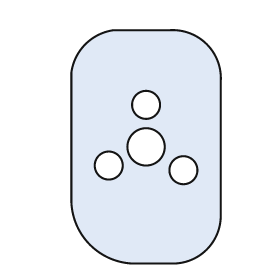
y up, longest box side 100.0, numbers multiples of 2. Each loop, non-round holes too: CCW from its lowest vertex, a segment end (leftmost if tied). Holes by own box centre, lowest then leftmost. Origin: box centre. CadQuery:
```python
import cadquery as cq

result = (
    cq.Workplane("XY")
    .moveTo(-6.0, -50.0)
    .lineTo(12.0, -50.0)
    .threePointArc((26.0, -44.0), (32.0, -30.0))
    .lineTo(32.0, 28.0)
    .threePointArc((26.0, 44.0), (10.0, 50.0))
    .lineTo(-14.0, 50.0)
    .threePointArc((-26.0, 44.0), (-32.0, 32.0))
    .lineTo(-32.0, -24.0)
    .threePointArc((-24.0, -42.0), (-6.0, -50.0))
    .close()
    .moveTo(16.0, -10.0)
    .circle(6.0)
    .moveTo(-16.0, -8.0)
    .circle(6.0)
    .moveTo(0.0, 0.0)
    .circle(8.0)
    .moveTo(0.0, 18.0)
    .circle(6.0)
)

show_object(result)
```